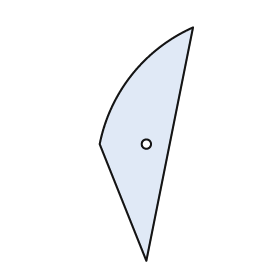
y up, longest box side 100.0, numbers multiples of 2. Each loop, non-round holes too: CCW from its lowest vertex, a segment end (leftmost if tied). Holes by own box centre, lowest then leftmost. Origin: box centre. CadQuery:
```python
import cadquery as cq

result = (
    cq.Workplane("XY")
    .moveTo(0.0, -50.0)
    .lineTo(20.0, 50.0)
    .threePointArc((-6.0, 30.0), (-20.0, 0.0))
    .close()
    .moveTo(0.0, 0.0)
    .circle(2.0)
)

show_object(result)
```